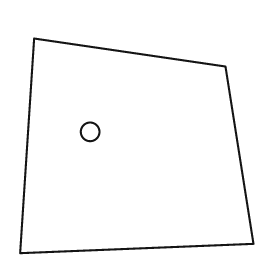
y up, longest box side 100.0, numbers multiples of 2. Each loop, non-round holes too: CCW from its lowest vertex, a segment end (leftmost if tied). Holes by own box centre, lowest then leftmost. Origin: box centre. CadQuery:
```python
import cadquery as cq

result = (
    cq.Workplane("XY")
    .moveTo(-50.0, -46.0)
    .lineTo(50.0, -42.0)
    .lineTo(38.0, 34.0)
    .lineTo(-44.0, 46.0)
    .close()
    .moveTo(-20.0, 6.0)
    .circle(4.0)
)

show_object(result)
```